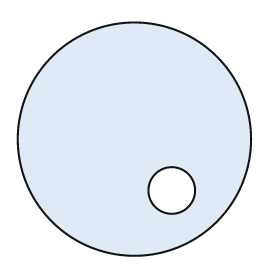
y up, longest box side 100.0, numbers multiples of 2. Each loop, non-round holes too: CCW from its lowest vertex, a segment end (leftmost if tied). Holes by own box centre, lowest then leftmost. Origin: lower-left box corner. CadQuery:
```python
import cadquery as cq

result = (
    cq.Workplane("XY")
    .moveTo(50.0, 50.0)
    .circle(50.0)
    .moveTo(66.0, 28.0)
    .circle(10.0)
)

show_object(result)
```